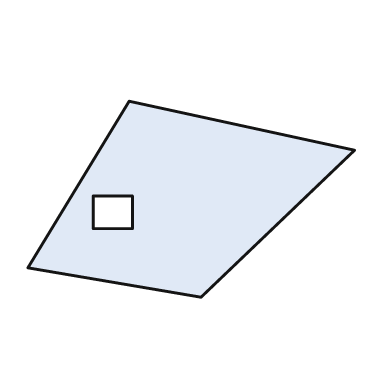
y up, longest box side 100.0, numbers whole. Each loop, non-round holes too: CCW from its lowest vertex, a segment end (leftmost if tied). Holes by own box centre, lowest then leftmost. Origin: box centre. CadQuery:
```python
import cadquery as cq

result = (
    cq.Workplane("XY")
    .moveTo(3.0, -30.0)
    .lineTo(50.0, 15.0)
    .lineTo(-19.0, 30.0)
    .lineTo(-50.0, -21.0)
    .close()
    .moveTo(-30.0, -9.0)
    .lineTo(-18.0, -9.0)
    .lineTo(-18.0, 1.0)
    .lineTo(-30.0, 1.0)
    .close()
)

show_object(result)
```